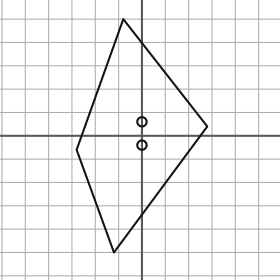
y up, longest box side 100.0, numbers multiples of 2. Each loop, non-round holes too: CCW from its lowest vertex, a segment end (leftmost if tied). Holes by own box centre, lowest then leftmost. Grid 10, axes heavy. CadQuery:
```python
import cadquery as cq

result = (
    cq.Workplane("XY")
    .moveTo(-12.0, -50.0)
    .lineTo(28.0, 4.0)
    .lineTo(-8.0, 50.0)
    .lineTo(-28.0, -6.0)
    .close()
    .moveTo(0.0, -4.0)
    .circle(2.0)
    .moveTo(0.0, 6.0)
    .circle(2.0)
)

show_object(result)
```